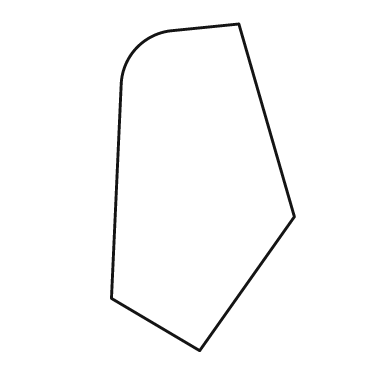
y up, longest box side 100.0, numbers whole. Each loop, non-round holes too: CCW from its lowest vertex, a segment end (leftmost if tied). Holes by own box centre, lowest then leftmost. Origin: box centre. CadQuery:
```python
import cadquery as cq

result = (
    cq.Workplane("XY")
    .moveTo(-1.0, -50.0)
    .lineTo(28.0, -9.0)
    .lineTo(11.0, 50.0)
    .lineTo(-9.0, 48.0)
    .threePointArc((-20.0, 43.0), (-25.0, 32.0))
    .lineTo(-28.0, -34.0)
    .close()
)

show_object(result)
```